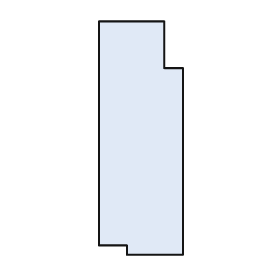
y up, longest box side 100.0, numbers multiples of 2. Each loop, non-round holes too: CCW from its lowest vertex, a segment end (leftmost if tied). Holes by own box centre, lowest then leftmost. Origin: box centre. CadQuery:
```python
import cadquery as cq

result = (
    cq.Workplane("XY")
    .moveTo(-6.0, -50.0)
    .lineTo(18.0, -50.0)
    .lineTo(18.0, 30.0)
    .lineTo(10.0, 30.0)
    .lineTo(10.0, 50.0)
    .lineTo(-18.0, 50.0)
    .lineTo(-18.0, -46.0)
    .lineTo(-6.0, -46.0)
    .close()
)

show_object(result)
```